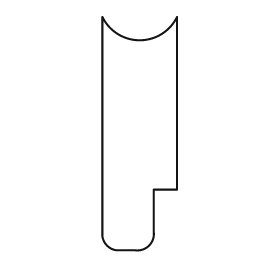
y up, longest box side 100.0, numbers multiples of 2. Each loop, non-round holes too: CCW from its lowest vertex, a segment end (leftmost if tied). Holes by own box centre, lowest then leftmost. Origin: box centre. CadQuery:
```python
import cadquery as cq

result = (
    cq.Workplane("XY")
    .moveTo(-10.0, -50.0)
    .lineTo(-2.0, -50.0)
    .threePointArc((4.0, -48.0), (6.0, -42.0))
    .lineTo(6.0, -24.0)
    .lineTo(16.0, -24.0)
    .lineTo(16.0, 50.0)
    .threePointArc((0.0, 40.0), (-16.0, 50.0))
    .lineTo(-16.0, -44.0)
    .threePointArc((-14.0, -48.0), (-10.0, -50.0))
    .close()
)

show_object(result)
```